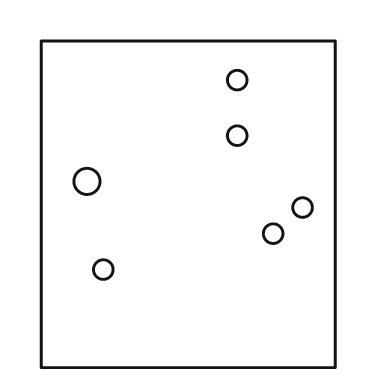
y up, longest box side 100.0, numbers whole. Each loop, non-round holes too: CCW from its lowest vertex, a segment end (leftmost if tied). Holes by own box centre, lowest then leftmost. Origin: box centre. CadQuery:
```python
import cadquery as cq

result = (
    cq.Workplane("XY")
    .moveTo(-45.0, -50.0)
    .lineTo(45.0, -50.0)
    .lineTo(45.0, 50.0)
    .lineTo(-45.0, 50.0)
    .close()
    .moveTo(-26.0, -20.0)
    .circle(3.0)
    .moveTo(26.0, -9.0)
    .circle(3.0)
    .moveTo(35.0, -1.0)
    .circle(3.0)
    .moveTo(-31.0, 7.0)
    .circle(4.0)
    .moveTo(15.0, 21.0)
    .circle(3.0)
    .moveTo(15.0, 38.0)
    .circle(3.0)
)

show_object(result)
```